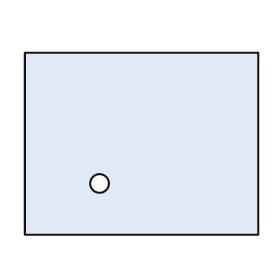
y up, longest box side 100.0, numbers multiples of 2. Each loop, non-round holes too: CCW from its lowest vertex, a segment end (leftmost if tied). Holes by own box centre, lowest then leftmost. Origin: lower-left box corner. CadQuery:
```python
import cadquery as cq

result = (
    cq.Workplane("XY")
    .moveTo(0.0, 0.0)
    .lineTo(100.0, 0.0)
    .lineTo(100.0, 78.0)
    .lineTo(0.0, 78.0)
    .close()
    .moveTo(32.0, 22.0)
    .circle(4.0)
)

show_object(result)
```